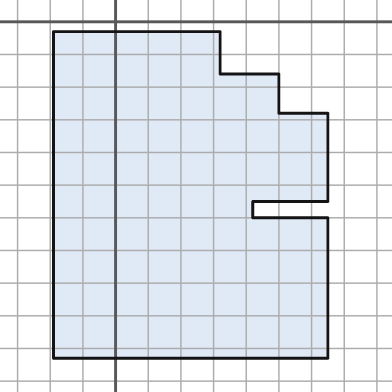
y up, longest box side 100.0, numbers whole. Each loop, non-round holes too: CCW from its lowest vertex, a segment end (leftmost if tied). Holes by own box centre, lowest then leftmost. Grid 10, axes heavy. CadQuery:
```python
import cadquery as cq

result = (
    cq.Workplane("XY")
    .moveTo(-19.0, -103.0)
    .lineTo(65.0, -103.0)
    .lineTo(65.0, -60.0)
    .lineTo(42.0, -60.0)
    .lineTo(42.0, -55.0)
    .lineTo(65.0, -55.0)
    .lineTo(65.0, -28.0)
    .lineTo(50.0, -28.0)
    .lineTo(50.0, -16.0)
    .lineTo(32.0, -16.0)
    .lineTo(32.0, -3.0)
    .lineTo(-19.0, -3.0)
    .close()
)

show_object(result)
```